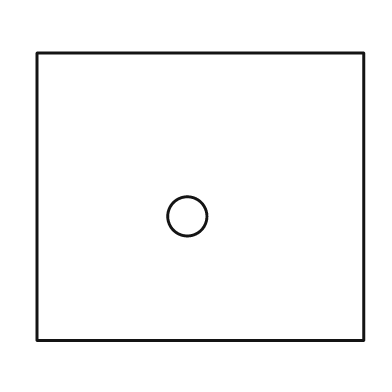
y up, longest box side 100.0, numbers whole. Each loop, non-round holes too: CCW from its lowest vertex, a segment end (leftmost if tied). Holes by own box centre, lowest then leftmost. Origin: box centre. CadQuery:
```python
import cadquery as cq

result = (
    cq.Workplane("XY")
    .moveTo(-50.0, -44.0)
    .lineTo(50.0, -44.0)
    .lineTo(50.0, 44.0)
    .lineTo(-50.0, 44.0)
    .close()
    .moveTo(-4.0, -6.0)
    .circle(6.0)
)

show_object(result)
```